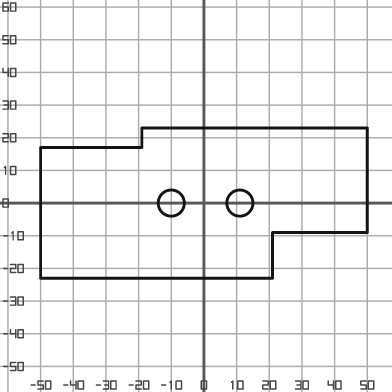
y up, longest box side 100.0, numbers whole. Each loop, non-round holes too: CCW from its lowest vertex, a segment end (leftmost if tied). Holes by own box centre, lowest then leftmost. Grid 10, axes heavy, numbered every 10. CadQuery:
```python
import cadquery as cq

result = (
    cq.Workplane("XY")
    .moveTo(-50.0, -23.0)
    .lineTo(21.0, -23.0)
    .lineTo(21.0, -9.0)
    .lineTo(50.0, -9.0)
    .lineTo(50.0, 23.0)
    .lineTo(-19.0, 23.0)
    .lineTo(-19.0, 17.0)
    .lineTo(-50.0, 17.0)
    .close()
    .moveTo(-10.0, 0.0)
    .circle(4.0)
    .moveTo(11.0, 0.0)
    .circle(4.0)
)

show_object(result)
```